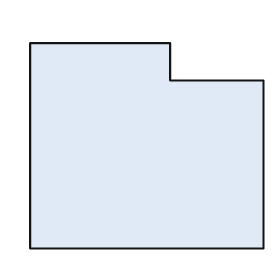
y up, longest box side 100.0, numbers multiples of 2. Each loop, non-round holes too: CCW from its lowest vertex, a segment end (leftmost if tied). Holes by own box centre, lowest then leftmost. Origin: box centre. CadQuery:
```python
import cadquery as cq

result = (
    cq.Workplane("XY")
    .moveTo(-50.0, -44.0)
    .lineTo(50.0, -44.0)
    .lineTo(50.0, 28.0)
    .lineTo(10.0, 28.0)
    .lineTo(10.0, 44.0)
    .lineTo(-50.0, 44.0)
    .close()
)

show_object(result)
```